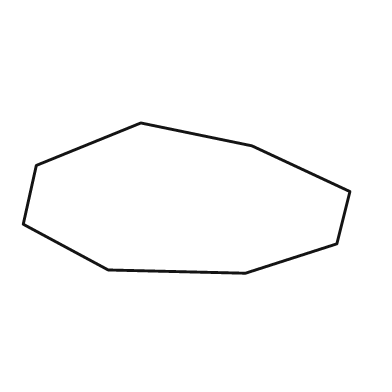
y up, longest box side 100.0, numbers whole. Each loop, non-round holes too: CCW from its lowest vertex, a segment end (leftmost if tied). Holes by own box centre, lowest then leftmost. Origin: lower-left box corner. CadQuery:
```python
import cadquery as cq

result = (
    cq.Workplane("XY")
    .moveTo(68.0, 0.0)
    .lineTo(96.0, 9.0)
    .lineTo(100.0, 25.0)
    .lineTo(70.0, 39.0)
    .lineTo(36.0, 46.0)
    .lineTo(4.0, 33.0)
    .lineTo(0.0, 15.0)
    .lineTo(26.0, 1.0)
    .close()
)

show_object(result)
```